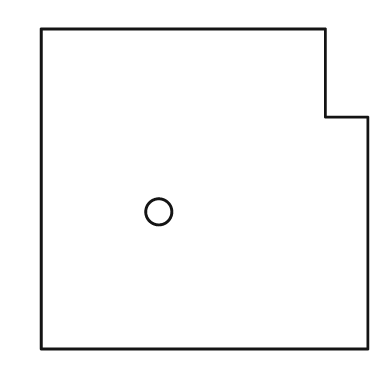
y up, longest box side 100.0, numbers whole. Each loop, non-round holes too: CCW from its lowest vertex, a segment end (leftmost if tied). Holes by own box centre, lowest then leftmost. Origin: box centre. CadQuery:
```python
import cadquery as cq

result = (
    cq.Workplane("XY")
    .moveTo(-50.0, -49.0)
    .lineTo(50.0, -49.0)
    .lineTo(50.0, 22.0)
    .lineTo(37.0, 22.0)
    .lineTo(37.0, 49.0)
    .lineTo(-50.0, 49.0)
    .close()
    .moveTo(-14.0, -7.0)
    .circle(4.0)
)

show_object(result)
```